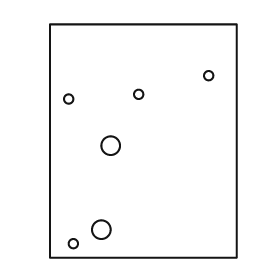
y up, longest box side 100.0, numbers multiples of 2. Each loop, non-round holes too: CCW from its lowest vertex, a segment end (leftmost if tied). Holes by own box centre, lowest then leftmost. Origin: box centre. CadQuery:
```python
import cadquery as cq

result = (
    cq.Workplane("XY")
    .moveTo(-40.0, -50.0)
    .lineTo(40.0, -50.0)
    .lineTo(40.0, 50.0)
    .lineTo(-40.0, 50.0)
    .close()
    .moveTo(-30.0, -44.0)
    .circle(2.0)
    .moveTo(-18.0, -38.0)
    .circle(4.0)
    .moveTo(-14.0, -2.0)
    .circle(4.0)
    .moveTo(-32.0, 18.0)
    .circle(2.0)
    .moveTo(-2.0, 20.0)
    .circle(2.0)
    .moveTo(28.0, 28.0)
    .circle(2.0)
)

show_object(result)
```